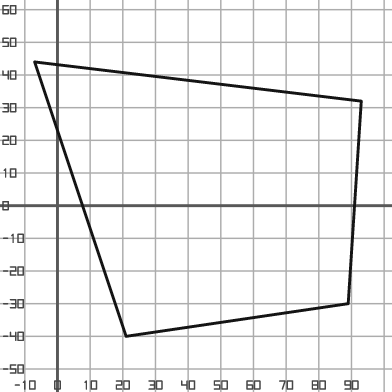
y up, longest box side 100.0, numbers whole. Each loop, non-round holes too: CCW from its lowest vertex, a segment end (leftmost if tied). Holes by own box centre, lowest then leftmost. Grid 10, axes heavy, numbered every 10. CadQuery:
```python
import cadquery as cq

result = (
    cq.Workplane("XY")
    .moveTo(21.0, -40.0)
    .lineTo(89.0, -30.0)
    .lineTo(93.0, 32.0)
    .lineTo(-7.0, 44.0)
    .close()
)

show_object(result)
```